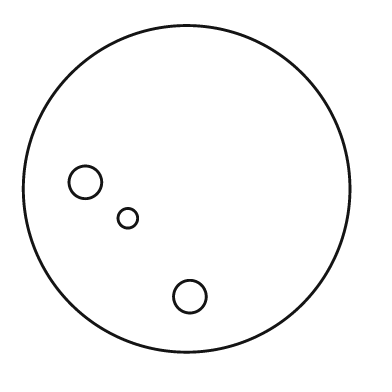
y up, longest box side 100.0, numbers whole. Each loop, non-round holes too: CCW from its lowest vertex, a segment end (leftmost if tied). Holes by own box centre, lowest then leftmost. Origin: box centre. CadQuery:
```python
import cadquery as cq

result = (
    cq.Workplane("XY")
    .moveTo(0.0, 0.0)
    .circle(50.0)
    .moveTo(1.0, -33.0)
    .circle(5.0)
    .moveTo(-18.0, -9.0)
    .circle(3.0)
    .moveTo(-31.0, 2.0)
    .circle(5.0)
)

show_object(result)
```